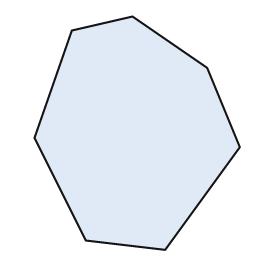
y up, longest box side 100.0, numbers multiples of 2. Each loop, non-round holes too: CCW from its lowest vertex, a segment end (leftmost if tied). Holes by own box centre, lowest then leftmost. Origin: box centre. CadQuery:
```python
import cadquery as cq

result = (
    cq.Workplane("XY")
    .moveTo(12.0, -50.0)
    .lineTo(44.0, -6.0)
    .lineTo(30.0, 28.0)
    .lineTo(-2.0, 50.0)
    .lineTo(-28.0, 44.0)
    .lineTo(-44.0, -2.0)
    .lineTo(-22.0, -46.0)
    .close()
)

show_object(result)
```